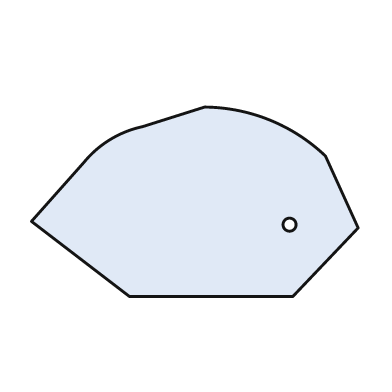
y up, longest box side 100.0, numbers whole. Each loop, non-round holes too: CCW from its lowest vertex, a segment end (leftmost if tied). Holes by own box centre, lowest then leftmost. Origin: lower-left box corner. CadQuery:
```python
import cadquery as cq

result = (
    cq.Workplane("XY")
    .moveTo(30.0, 0.0)
    .lineTo(80.0, 0.0)
    .lineTo(100.0, 21.0)
    .lineTo(90.0, 43.0)
    .threePointArc((73.0, 54.0), (53.0, 58.0))
    .lineTo(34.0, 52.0)
    .threePointArc((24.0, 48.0), (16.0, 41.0))
    .lineTo(0.0, 23.0)
    .close()
    .moveTo(79.0, 22.0)
    .circle(2.0)
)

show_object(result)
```